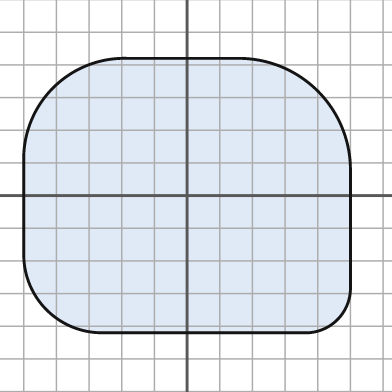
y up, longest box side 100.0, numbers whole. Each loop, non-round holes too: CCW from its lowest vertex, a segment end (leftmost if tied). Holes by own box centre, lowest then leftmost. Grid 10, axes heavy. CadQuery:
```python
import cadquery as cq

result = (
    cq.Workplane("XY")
    .moveTo(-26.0, -42.0)
    .lineTo(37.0, -42.0)
    .threePointArc((46.0, -38.0), (50.0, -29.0))
    .lineTo(50.0, 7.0)
    .threePointArc((40.0, 32.0), (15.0, 42.0))
    .lineTo(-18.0, 42.0)
    .threePointArc((-41.0, 33.0), (-50.0, 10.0))
    .lineTo(-50.0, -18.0)
    .threePointArc((-43.0, -35.0), (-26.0, -42.0))
    .close()
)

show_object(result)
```